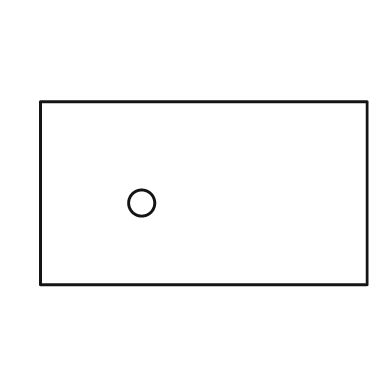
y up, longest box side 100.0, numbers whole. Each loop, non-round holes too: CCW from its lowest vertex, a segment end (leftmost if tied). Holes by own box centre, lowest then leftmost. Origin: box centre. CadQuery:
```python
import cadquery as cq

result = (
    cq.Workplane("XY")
    .moveTo(-50.0, -28.0)
    .lineTo(50.0, -28.0)
    .lineTo(50.0, 28.0)
    .lineTo(-50.0, 28.0)
    .close()
    .moveTo(-19.0, -3.0)
    .circle(4.0)
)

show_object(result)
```